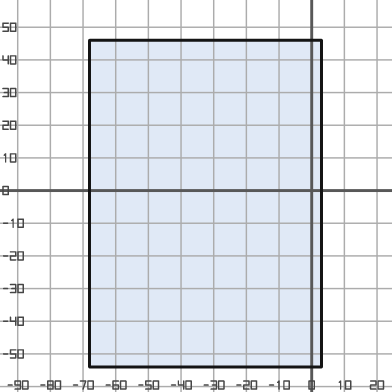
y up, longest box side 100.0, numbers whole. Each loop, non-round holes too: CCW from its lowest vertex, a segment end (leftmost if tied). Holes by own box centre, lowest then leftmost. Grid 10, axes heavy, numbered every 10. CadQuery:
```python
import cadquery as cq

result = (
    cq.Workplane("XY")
    .moveTo(-68.0, -54.0)
    .lineTo(3.0, -54.0)
    .lineTo(3.0, 46.0)
    .lineTo(-68.0, 46.0)
    .close()
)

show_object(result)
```